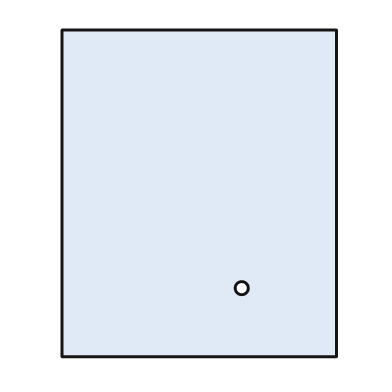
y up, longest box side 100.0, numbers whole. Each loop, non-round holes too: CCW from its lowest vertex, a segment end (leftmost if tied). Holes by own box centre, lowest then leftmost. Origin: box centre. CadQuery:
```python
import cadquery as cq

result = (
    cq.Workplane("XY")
    .moveTo(-42.0, -50.0)
    .lineTo(42.0, -50.0)
    .lineTo(42.0, 50.0)
    .lineTo(-42.0, 50.0)
    .close()
    .moveTo(13.0, -29.0)
    .circle(2.0)
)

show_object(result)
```